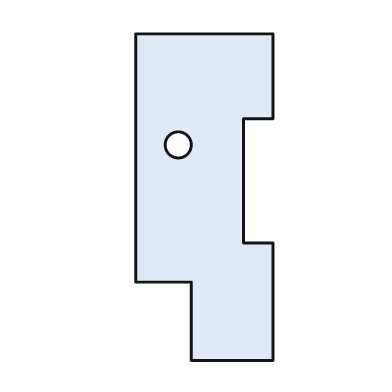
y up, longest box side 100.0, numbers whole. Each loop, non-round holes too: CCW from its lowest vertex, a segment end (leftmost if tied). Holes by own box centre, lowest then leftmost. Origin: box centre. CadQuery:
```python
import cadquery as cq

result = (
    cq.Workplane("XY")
    .moveTo(-4.0, -50.0)
    .lineTo(21.0, -50.0)
    .lineTo(21.0, -14.0)
    .lineTo(12.0, -14.0)
    .lineTo(12.0, 24.0)
    .lineTo(21.0, 24.0)
    .lineTo(21.0, 50.0)
    .lineTo(-21.0, 50.0)
    .lineTo(-21.0, -26.0)
    .lineTo(-4.0, -26.0)
    .close()
    .moveTo(-8.0, 16.0)
    .circle(4.0)
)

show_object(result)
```